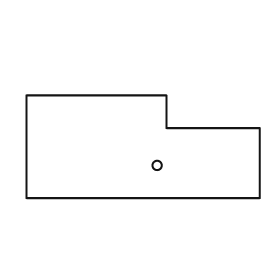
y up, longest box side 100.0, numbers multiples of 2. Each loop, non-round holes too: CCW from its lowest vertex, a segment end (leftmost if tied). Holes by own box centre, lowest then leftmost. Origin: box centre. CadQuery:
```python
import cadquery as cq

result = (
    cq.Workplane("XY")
    .moveTo(-50.0, -22.0)
    .lineTo(50.0, -22.0)
    .lineTo(50.0, 8.0)
    .lineTo(10.0, 8.0)
    .lineTo(10.0, 22.0)
    .lineTo(-50.0, 22.0)
    .close()
    .moveTo(6.0, -8.0)
    .circle(2.0)
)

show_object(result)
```